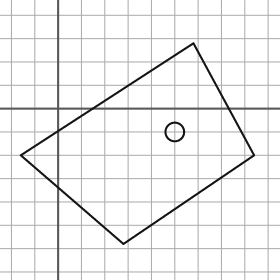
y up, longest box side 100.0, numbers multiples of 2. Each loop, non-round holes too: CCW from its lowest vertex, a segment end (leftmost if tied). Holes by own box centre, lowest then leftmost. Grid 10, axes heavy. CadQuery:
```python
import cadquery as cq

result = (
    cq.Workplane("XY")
    .moveTo(28.0, -58.0)
    .lineTo(84.0, -20.0)
    .lineTo(58.0, 28.0)
    .lineTo(-16.0, -20.0)
    .close()
    .moveTo(50.0, -10.0)
    .circle(4.0)
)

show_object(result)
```